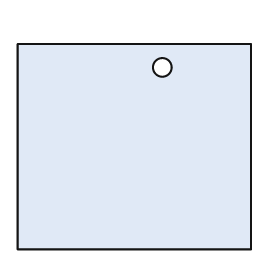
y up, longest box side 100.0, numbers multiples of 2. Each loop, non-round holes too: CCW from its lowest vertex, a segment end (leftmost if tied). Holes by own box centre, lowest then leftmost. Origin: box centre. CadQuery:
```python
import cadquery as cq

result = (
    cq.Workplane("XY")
    .moveTo(-50.0, -44.0)
    .lineTo(50.0, -44.0)
    .lineTo(50.0, 44.0)
    .lineTo(-50.0, 44.0)
    .close()
    .moveTo(12.0, 34.0)
    .circle(4.0)
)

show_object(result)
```